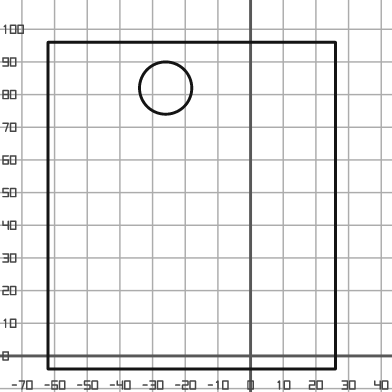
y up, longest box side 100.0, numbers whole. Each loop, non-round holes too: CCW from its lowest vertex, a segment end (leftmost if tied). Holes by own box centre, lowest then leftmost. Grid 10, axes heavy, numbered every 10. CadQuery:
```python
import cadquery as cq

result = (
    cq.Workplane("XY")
    .moveTo(-62.0, -4.0)
    .lineTo(26.0, -4.0)
    .lineTo(26.0, 96.0)
    .lineTo(-62.0, 96.0)
    .close()
    .moveTo(-26.0, 82.0)
    .circle(8.0)
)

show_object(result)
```